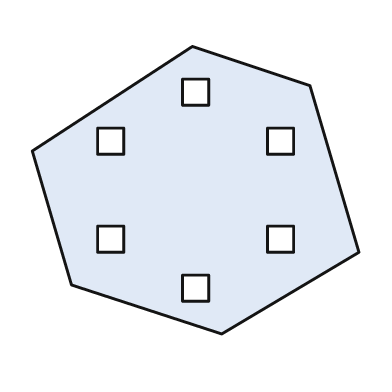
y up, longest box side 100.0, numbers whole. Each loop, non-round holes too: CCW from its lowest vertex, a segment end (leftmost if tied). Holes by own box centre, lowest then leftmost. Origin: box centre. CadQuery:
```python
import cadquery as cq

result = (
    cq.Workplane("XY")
    .moveTo(8.0, -44.0)
    .lineTo(50.0, -19.0)
    .lineTo(35.0, 32.0)
    .lineTo(-1.0, 44.0)
    .lineTo(-50.0, 12.0)
    .lineTo(-38.0, -29.0)
    .close()
    .moveTo(-4.0, -34.0)
    .lineTo(4.0, -34.0)
    .lineTo(4.0, -26.0)
    .lineTo(-4.0, -26.0)
    .close()
    .moveTo(-30.0, -19.0)
    .lineTo(-22.0, -19.0)
    .lineTo(-22.0, -11.0)
    .lineTo(-30.0, -11.0)
    .close()
    .moveTo(22.0, -19.0)
    .lineTo(30.0, -19.0)
    .lineTo(30.0, -11.0)
    .lineTo(22.0, -11.0)
    .close()
    .moveTo(-30.0, 11.0)
    .lineTo(-22.0, 11.0)
    .lineTo(-22.0, 19.0)
    .lineTo(-30.0, 19.0)
    .close()
    .moveTo(22.0, 11.0)
    .lineTo(30.0, 11.0)
    .lineTo(30.0, 19.0)
    .lineTo(22.0, 19.0)
    .close()
    .moveTo(-4.0, 26.0)
    .lineTo(4.0, 26.0)
    .lineTo(4.0, 34.0)
    .lineTo(-4.0, 34.0)
    .close()
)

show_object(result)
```